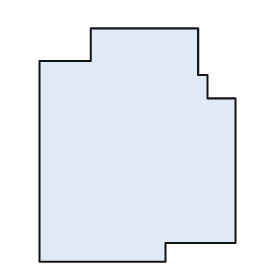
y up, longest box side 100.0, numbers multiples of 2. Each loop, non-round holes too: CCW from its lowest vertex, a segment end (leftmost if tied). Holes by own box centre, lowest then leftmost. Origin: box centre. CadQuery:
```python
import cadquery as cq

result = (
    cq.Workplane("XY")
    .moveTo(-42.0, -50.0)
    .lineTo(12.0, -50.0)
    .lineTo(12.0, -42.0)
    .lineTo(42.0, -42.0)
    .lineTo(42.0, 20.0)
    .lineTo(30.0, 20.0)
    .lineTo(30.0, 30.0)
    .lineTo(26.0, 30.0)
    .lineTo(26.0, 50.0)
    .lineTo(-20.0, 50.0)
    .lineTo(-20.0, 36.0)
    .lineTo(-42.0, 36.0)
    .close()
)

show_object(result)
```